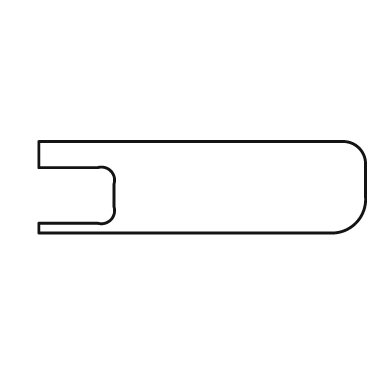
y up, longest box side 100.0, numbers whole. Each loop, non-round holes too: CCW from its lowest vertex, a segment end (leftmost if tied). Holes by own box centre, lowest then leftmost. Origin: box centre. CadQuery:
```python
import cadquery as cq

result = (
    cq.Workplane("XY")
    .moveTo(-50.0, -14.0)
    .lineTo(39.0, -14.0)
    .threePointArc((47.0, -11.0), (50.0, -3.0))
    .lineTo(50.0, 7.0)
    .threePointArc((48.0, 12.0), (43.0, 14.0))
    .lineTo(-50.0, 14.0)
    .lineTo(-50.0, 6.0)
    .lineTo(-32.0, 6.0)
    .threePointArc((-28.0, 5.0), (-27.0, 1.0))
    .lineTo(-27.0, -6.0)
    .threePointArc((-28.0, -10.0), (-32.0, -11.0))
    .lineTo(-50.0, -11.0)
    .close()
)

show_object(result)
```